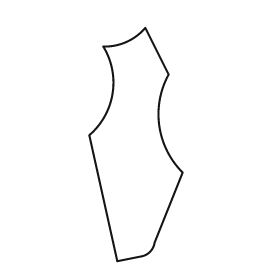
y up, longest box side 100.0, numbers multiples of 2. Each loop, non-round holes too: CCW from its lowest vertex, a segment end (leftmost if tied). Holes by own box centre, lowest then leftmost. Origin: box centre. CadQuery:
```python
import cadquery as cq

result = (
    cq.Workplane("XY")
    .moveTo(-8.0, -50.0)
    .lineTo(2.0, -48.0)
    .threePointArc((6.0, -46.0), (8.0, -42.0))
    .lineTo(20.0, -12.0)
    .threePointArc((10.0, 8.0), (14.0, 30.0))
    .lineTo(4.0, 50.0)
    .threePointArc((-4.0, 44.0), (-14.0, 42.0))
    .threePointArc((-10.0, 22.0), (-20.0, 4.0))
    .close()
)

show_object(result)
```